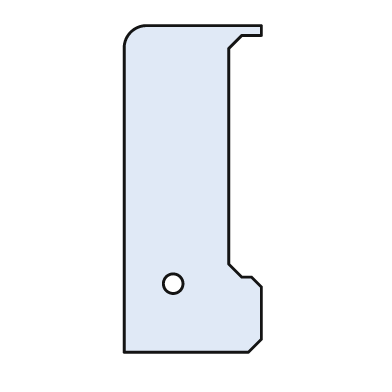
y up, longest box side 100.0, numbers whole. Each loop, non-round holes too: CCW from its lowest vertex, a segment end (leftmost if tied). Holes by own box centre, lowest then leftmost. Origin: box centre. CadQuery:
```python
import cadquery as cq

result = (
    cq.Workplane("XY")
    .moveTo(-21.0, -50.0)
    .lineTo(17.0, -50.0)
    .lineTo(21.0, -46.0)
    .lineTo(21.0, -30.0)
    .lineTo(18.0, -27.0)
    .lineTo(15.0, -27.0)
    .lineTo(11.0, -23.0)
    .lineTo(11.0, 43.0)
    .lineTo(15.0, 47.0)
    .lineTo(21.0, 47.0)
    .lineTo(21.0, 50.0)
    .lineTo(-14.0, 50.0)
    .threePointArc((-19.0, 48.0), (-21.0, 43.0))
    .close()
    .moveTo(-6.0, -29.0)
    .circle(3.0)
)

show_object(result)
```